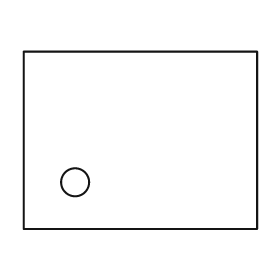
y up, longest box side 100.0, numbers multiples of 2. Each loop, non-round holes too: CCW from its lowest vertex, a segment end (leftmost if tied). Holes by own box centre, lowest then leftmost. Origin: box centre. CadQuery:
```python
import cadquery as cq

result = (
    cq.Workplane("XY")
    .moveTo(-50.0, -38.0)
    .lineTo(50.0, -38.0)
    .lineTo(50.0, 38.0)
    .lineTo(-50.0, 38.0)
    .close()
    .moveTo(-28.0, -18.0)
    .circle(6.0)
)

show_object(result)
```